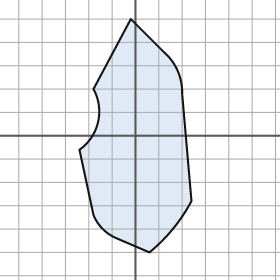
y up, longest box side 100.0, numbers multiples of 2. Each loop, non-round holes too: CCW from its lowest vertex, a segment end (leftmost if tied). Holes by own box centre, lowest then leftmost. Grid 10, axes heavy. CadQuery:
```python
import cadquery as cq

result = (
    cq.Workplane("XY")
    .moveTo(6.0, -50.0)
    .threePointArc((16.0, -40.0), (24.0, -28.0))
    .lineTo(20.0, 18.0)
    .threePointArc((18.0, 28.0), (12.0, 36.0))
    .lineTo(-2.0, 50.0)
    .lineTo(-18.0, 20.0)
    .threePointArc((-16.0, 6.0), (-24.0, -6.0))
    .lineTo(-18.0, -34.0)
    .threePointArc((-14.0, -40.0), (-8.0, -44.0))
    .close()
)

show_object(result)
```